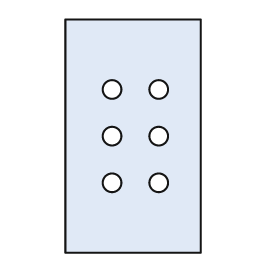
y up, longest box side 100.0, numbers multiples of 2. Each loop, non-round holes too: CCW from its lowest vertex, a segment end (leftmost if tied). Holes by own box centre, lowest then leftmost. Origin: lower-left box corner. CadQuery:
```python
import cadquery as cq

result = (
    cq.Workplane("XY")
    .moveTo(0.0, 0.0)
    .lineTo(58.0, 0.0)
    .lineTo(58.0, 100.0)
    .lineTo(0.0, 100.0)
    .close()
    .moveTo(20.0, 30.0)
    .circle(4.0)
    .moveTo(40.0, 30.0)
    .circle(4.0)
    .moveTo(20.0, 50.0)
    .circle(4.0)
    .moveTo(40.0, 50.0)
    .circle(4.0)
    .moveTo(20.0, 70.0)
    .circle(4.0)
    .moveTo(40.0, 70.0)
    .circle(4.0)
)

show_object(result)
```